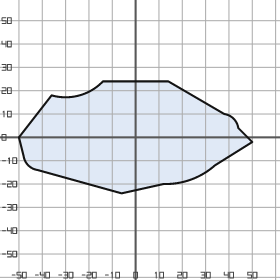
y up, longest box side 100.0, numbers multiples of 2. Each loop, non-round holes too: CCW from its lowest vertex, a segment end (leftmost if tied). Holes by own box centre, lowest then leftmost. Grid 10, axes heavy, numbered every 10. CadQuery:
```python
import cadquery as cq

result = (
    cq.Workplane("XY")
    .moveTo(-6.0, -24.0)
    .lineTo(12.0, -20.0)
    .threePointArc((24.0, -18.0), (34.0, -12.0))
    .lineTo(50.0, -2.0)
    .lineTo(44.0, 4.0)
    .threePointArc((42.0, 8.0), (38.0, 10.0))
    .lineTo(14.0, 24.0)
    .lineTo(-14.0, 24.0)
    .threePointArc((-24.0, 18.0), (-36.0, 18.0))
    .lineTo(-50.0, 0.0)
    .lineTo(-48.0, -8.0)
    .threePointArc((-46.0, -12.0), (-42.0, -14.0))
    .close()
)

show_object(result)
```